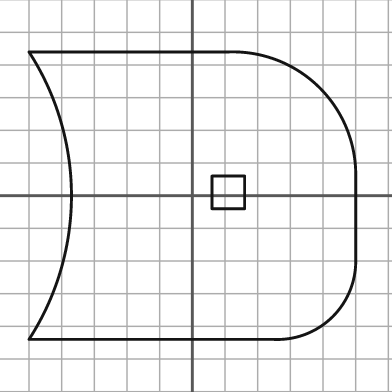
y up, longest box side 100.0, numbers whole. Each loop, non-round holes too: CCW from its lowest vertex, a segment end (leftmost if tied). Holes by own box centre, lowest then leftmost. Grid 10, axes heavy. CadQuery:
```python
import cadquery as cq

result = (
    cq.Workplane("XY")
    .moveTo(-50.0, -44.0)
    .lineTo(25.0, -44.0)
    .threePointArc((43.0, -37.0), (50.0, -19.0))
    .lineTo(50.0, 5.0)
    .threePointArc((39.0, 33.0), (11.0, 44.0))
    .lineTo(-50.0, 44.0)
    .threePointArc((-37.0, 0.0), (-50.0, -44.0))
    .close()
    .moveTo(6.0, -4.0)
    .lineTo(16.0, -4.0)
    .lineTo(16.0, 6.0)
    .lineTo(6.0, 6.0)
    .close()
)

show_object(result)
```